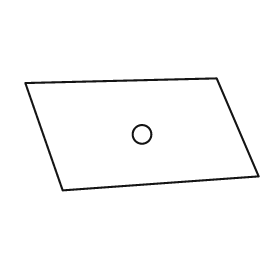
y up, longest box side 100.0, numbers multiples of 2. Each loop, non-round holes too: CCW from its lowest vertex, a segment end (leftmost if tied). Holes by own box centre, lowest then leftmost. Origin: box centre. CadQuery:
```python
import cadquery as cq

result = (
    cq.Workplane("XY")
    .moveTo(-34.0, -24.0)
    .lineTo(50.0, -18.0)
    .lineTo(32.0, 24.0)
    .lineTo(-50.0, 22.0)
    .close()
    .moveTo(0.0, 0.0)
    .circle(4.0)
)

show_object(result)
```